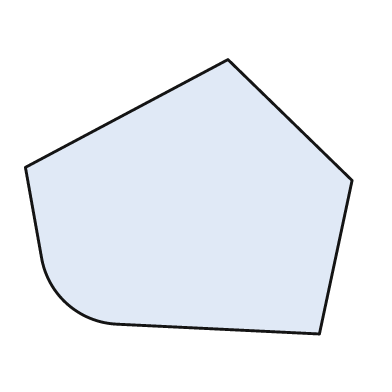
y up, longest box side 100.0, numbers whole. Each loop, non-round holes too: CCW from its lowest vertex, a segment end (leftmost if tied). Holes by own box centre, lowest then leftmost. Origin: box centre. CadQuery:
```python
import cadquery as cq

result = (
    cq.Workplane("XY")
    .moveTo(40.0, -42.0)
    .lineTo(50.0, 5.0)
    .lineTo(12.0, 42.0)
    .lineTo(-50.0, 9.0)
    .lineTo(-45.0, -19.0)
    .threePointArc((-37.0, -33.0), (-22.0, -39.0))
    .close()
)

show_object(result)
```